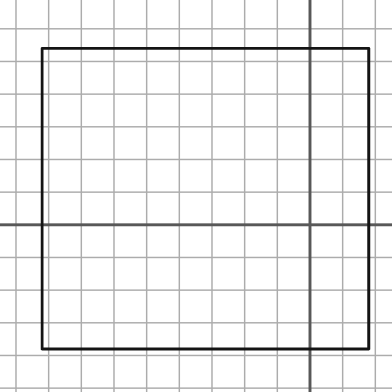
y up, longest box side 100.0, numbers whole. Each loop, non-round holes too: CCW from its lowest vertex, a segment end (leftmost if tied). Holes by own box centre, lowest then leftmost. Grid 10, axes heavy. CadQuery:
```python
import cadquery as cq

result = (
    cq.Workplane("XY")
    .moveTo(-82.0, -38.0)
    .lineTo(18.0, -38.0)
    .lineTo(18.0, 54.0)
    .lineTo(-82.0, 54.0)
    .close()
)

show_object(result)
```